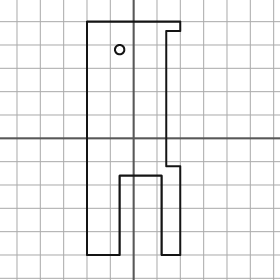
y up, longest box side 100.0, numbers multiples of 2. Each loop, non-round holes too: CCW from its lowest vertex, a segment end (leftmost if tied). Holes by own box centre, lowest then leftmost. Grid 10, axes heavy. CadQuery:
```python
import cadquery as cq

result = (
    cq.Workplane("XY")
    .moveTo(-20.0, -50.0)
    .lineTo(-6.0, -50.0)
    .lineTo(-6.0, -16.0)
    .lineTo(12.0, -16.0)
    .lineTo(12.0, -50.0)
    .lineTo(20.0, -50.0)
    .lineTo(20.0, -12.0)
    .lineTo(14.0, -12.0)
    .lineTo(14.0, 46.0)
    .lineTo(20.0, 46.0)
    .lineTo(20.0, 50.0)
    .lineTo(-20.0, 50.0)
    .close()
    .moveTo(-6.0, 38.0)
    .circle(2.0)
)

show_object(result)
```